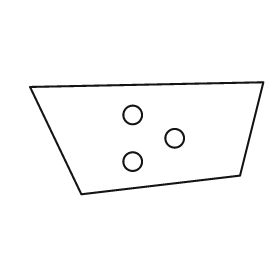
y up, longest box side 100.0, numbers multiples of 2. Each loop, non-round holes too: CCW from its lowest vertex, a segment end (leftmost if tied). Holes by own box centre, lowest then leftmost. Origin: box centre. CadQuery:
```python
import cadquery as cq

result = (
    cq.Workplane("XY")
    .moveTo(-28.0, -24.0)
    .lineTo(40.0, -16.0)
    .lineTo(50.0, 24.0)
    .lineTo(-50.0, 22.0)
    .close()
    .moveTo(-6.0, -10.0)
    .circle(4.0)
    .moveTo(12.0, 0.0)
    .circle(4.0)
    .moveTo(-6.0, 10.0)
    .circle(4.0)
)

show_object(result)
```